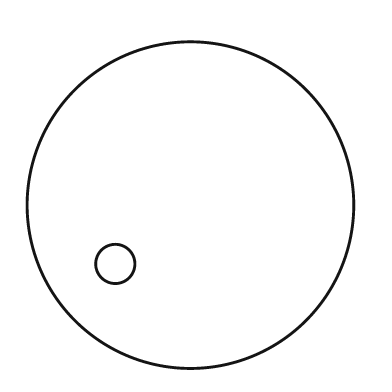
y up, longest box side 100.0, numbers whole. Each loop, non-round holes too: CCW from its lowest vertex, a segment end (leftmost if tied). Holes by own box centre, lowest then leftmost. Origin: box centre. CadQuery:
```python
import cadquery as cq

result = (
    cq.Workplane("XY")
    .moveTo(0.0, 0.0)
    .circle(50.0)
    .moveTo(-23.0, -18.0)
    .circle(6.0)
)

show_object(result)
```